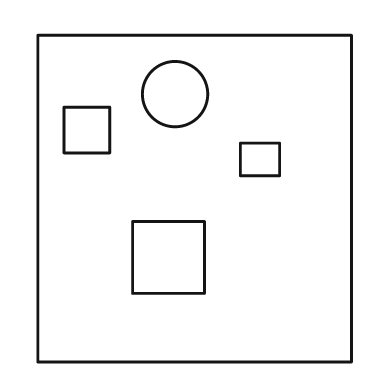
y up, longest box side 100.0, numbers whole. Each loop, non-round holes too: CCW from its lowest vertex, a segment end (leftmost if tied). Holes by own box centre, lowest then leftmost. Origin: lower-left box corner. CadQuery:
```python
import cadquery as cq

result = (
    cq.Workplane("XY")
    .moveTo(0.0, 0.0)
    .lineTo(96.0, 0.0)
    .lineTo(96.0, 100.0)
    .lineTo(0.0, 100.0)
    .close()
    .moveTo(29.0, 21.0)
    .lineTo(51.0, 21.0)
    .lineTo(51.0, 43.0)
    .lineTo(29.0, 43.0)
    .close()
    .moveTo(62.0, 57.0)
    .lineTo(74.0, 57.0)
    .lineTo(74.0, 67.0)
    .lineTo(62.0, 67.0)
    .close()
    .moveTo(8.0, 64.0)
    .lineTo(22.0, 64.0)
    .lineTo(22.0, 78.0)
    .lineTo(8.0, 78.0)
    .close()
    .moveTo(42.0, 82.0)
    .circle(10.0)
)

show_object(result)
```